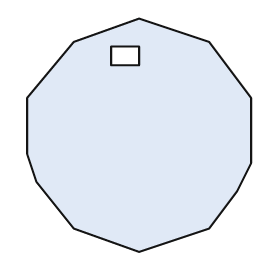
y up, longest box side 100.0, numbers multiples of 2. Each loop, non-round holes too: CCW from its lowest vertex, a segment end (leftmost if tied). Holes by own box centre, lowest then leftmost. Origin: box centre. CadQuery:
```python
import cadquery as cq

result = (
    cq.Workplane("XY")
    .moveTo(0.0, -50.0)
    .lineTo(30.0, -40.0)
    .lineTo(42.0, -24.0)
    .lineTo(48.0, -12.0)
    .lineTo(48.0, 16.0)
    .lineTo(30.0, 40.0)
    .lineTo(0.0, 50.0)
    .lineTo(-28.0, 40.0)
    .lineTo(-48.0, 16.0)
    .lineTo(-48.0, -8.0)
    .lineTo(-44.0, -20.0)
    .lineTo(-28.0, -40.0)
    .close()
    .moveTo(-12.0, 30.0)
    .lineTo(0.0, 30.0)
    .lineTo(0.0, 38.0)
    .lineTo(-12.0, 38.0)
    .close()
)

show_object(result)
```